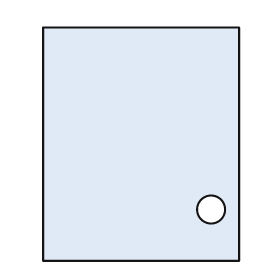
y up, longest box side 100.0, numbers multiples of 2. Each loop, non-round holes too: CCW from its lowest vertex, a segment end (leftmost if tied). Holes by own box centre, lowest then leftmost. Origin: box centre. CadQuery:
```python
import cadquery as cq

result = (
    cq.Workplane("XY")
    .moveTo(-42.0, -50.0)
    .lineTo(42.0, -50.0)
    .lineTo(42.0, 50.0)
    .lineTo(-42.0, 50.0)
    .close()
    .moveTo(30.0, -28.0)
    .circle(6.0)
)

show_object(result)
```